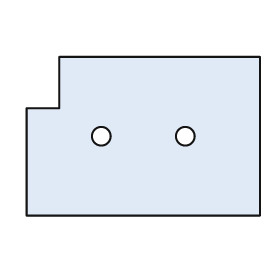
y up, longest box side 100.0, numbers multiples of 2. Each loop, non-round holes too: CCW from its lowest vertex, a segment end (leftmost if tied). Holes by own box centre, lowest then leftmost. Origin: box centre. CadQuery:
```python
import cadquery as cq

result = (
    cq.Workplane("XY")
    .moveTo(-50.0, -34.0)
    .lineTo(50.0, -34.0)
    .lineTo(50.0, 34.0)
    .lineTo(-36.0, 34.0)
    .lineTo(-36.0, 12.0)
    .lineTo(-50.0, 12.0)
    .close()
    .moveTo(-18.0, 0.0)
    .circle(4.0)
    .moveTo(18.0, 0.0)
    .circle(4.0)
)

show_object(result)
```